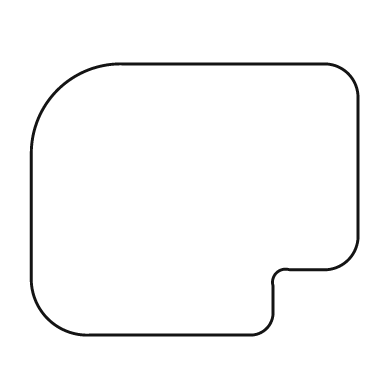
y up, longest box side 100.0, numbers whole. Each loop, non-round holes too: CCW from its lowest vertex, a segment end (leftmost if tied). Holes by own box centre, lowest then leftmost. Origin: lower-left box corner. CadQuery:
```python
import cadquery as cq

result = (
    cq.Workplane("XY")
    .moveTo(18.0, 0.0)
    .lineTo(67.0, 0.0)
    .threePointArc((72.0, 2.0), (74.0, 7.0))
    .lineTo(74.0, 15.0)
    .threePointArc((75.0, 19.0), (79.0, 20.0))
    .lineTo(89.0, 20.0)
    .threePointArc((97.0, 23.0), (100.0, 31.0))
    .lineTo(100.0, 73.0)
    .threePointArc((97.0, 80.0), (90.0, 83.0))
    .lineTo(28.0, 83.0)
    .threePointArc((8.0, 75.0), (0.0, 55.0))
    .lineTo(0.0, 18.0)
    .threePointArc((5.0, 5.0), (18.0, 0.0))
    .close()
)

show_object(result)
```